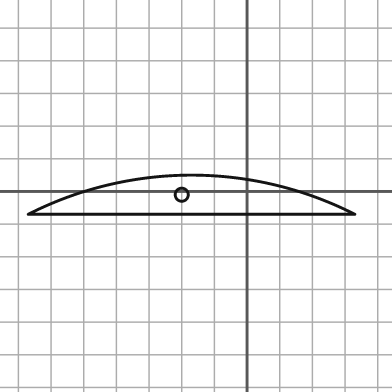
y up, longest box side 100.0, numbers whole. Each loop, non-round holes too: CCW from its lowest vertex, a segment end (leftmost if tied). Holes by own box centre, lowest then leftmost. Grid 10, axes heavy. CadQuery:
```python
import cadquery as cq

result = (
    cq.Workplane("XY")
    .moveTo(-67.0, -7.0)
    .lineTo(33.0, -7.0)
    .threePointArc((-17.0, 5.0), (-67.0, -7.0))
    .close()
    .moveTo(-20.0, -1.0)
    .circle(2.0)
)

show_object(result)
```